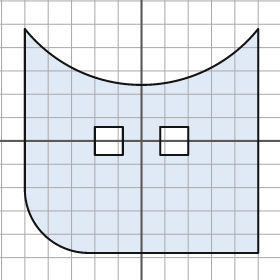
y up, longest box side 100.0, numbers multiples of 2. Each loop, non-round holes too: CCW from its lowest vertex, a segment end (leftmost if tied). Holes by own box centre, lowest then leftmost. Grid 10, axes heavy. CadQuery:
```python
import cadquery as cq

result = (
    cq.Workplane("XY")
    .moveTo(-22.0, -48.0)
    .lineTo(50.0, -48.0)
    .lineTo(50.0, 48.0)
    .threePointArc((0.0, 24.0), (-50.0, 48.0))
    .lineTo(-50.0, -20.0)
    .threePointArc((-42.0, -40.0), (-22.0, -48.0))
    .close()
    .moveTo(-20.0, -6.0)
    .lineTo(-8.0, -6.0)
    .lineTo(-8.0, 6.0)
    .lineTo(-20.0, 6.0)
    .close()
    .moveTo(8.0, -6.0)
    .lineTo(20.0, -6.0)
    .lineTo(20.0, 6.0)
    .lineTo(8.0, 6.0)
    .close()
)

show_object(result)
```